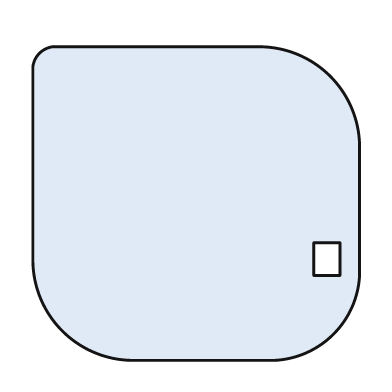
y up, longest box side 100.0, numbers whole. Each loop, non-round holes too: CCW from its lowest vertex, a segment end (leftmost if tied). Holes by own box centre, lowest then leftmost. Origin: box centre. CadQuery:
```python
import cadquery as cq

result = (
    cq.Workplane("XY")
    .moveTo(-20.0, -48.0)
    .lineTo(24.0, -48.0)
    .threePointArc((42.0, -40.0), (50.0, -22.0))
    .lineTo(50.0, 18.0)
    .threePointArc((41.0, 39.0), (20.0, 48.0))
    .lineTo(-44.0, 48.0)
    .threePointArc((-48.0, 46.0), (-50.0, 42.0))
    .lineTo(-50.0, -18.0)
    .threePointArc((-41.0, -39.0), (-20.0, -48.0))
    .close()
    .moveTo(36.0, -22.0)
    .lineTo(44.0, -22.0)
    .lineTo(44.0, -12.0)
    .lineTo(36.0, -12.0)
    .close()
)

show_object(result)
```